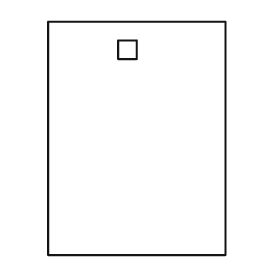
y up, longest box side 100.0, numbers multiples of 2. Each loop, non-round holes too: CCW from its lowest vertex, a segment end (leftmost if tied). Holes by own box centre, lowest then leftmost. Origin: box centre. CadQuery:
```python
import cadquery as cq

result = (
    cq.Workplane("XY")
    .moveTo(-38.0, -50.0)
    .lineTo(38.0, -50.0)
    .lineTo(38.0, 50.0)
    .lineTo(-38.0, 50.0)
    .close()
    .moveTo(-8.0, 34.0)
    .lineTo(0.0, 34.0)
    .lineTo(0.0, 42.0)
    .lineTo(-8.0, 42.0)
    .close()
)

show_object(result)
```